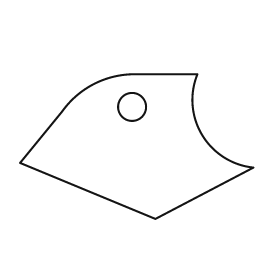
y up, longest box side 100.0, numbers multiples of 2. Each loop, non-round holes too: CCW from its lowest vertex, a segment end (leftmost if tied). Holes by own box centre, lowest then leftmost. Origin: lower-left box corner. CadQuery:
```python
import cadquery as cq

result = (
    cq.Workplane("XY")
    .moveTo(58.0, 0.0)
    .lineTo(100.0, 22.0)
    .threePointArc((78.0, 36.0), (76.0, 62.0))
    .lineTo(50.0, 62.0)
    .threePointArc((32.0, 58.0), (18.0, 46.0))
    .lineTo(0.0, 24.0)
    .close()
    .moveTo(48.0, 48.0)
    .circle(6.0)
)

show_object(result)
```